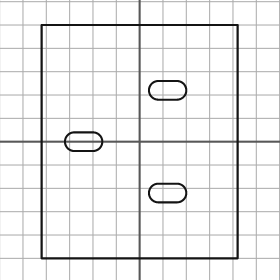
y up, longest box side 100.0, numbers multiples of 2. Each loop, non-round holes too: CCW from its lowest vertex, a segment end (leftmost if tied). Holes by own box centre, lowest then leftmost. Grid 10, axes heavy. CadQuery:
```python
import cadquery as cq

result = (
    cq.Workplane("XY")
    .moveTo(-42.0, -50.0)
    .lineTo(42.0, -50.0)
    .lineTo(42.0, 50.0)
    .lineTo(-42.0, 50.0)
    .close()
    .moveTo(8.0, -26.0)
    .lineTo(16.0, -26.0)
    .threePointArc((20.0, -22.0), (16.0, -18.0))
    .lineTo(8.0, -18.0)
    .threePointArc((4.0, -22.0), (8.0, -26.0))
    .close()
    .moveTo(-28.0, -4.0)
    .lineTo(-20.0, -4.0)
    .threePointArc((-16.0, 0.0), (-20.0, 4.0))
    .lineTo(-28.0, 4.0)
    .threePointArc((-32.0, 0.0), (-28.0, -4.0))
    .close()
    .moveTo(8.0, 18.0)
    .lineTo(16.0, 18.0)
    .threePointArc((20.0, 22.0), (16.0, 26.0))
    .lineTo(8.0, 26.0)
    .threePointArc((4.0, 22.0), (8.0, 18.0))
    .close()
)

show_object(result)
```